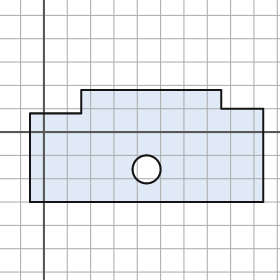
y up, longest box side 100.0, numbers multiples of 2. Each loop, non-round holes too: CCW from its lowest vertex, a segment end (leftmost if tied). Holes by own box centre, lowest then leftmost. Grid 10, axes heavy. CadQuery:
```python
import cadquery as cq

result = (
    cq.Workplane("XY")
    .moveTo(-6.0, -30.0)
    .lineTo(94.0, -30.0)
    .lineTo(94.0, 10.0)
    .lineTo(76.0, 10.0)
    .lineTo(76.0, 18.0)
    .lineTo(16.0, 18.0)
    .lineTo(16.0, 8.0)
    .lineTo(-6.0, 8.0)
    .close()
    .moveTo(44.0, -16.0)
    .circle(6.0)
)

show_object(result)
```